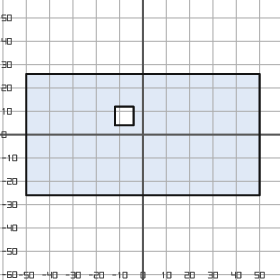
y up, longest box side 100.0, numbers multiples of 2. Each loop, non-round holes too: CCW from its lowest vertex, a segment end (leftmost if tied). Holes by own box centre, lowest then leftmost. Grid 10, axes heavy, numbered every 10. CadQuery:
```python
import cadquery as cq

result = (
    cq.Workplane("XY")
    .moveTo(-50.0, -26.0)
    .lineTo(50.0, -26.0)
    .lineTo(50.0, 26.0)
    .lineTo(-50.0, 26.0)
    .close()
    .moveTo(-12.0, 4.0)
    .lineTo(-4.0, 4.0)
    .lineTo(-4.0, 12.0)
    .lineTo(-12.0, 12.0)
    .close()
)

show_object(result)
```